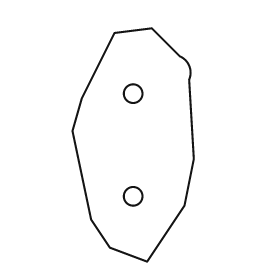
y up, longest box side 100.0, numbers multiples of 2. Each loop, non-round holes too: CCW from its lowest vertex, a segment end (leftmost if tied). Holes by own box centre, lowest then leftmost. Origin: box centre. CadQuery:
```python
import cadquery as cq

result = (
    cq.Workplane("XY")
    .moveTo(6.0, -50.0)
    .lineTo(22.0, -26.0)
    .lineTo(26.0, -6.0)
    .lineTo(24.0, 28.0)
    .threePointArc((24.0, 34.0), (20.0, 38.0))
    .lineTo(8.0, 50.0)
    .lineTo(-8.0, 48.0)
    .lineTo(-22.0, 20.0)
    .lineTo(-26.0, 6.0)
    .lineTo(-18.0, -32.0)
    .lineTo(-10.0, -44.0)
    .close()
    .moveTo(0.0, -22.0)
    .circle(4.0)
    .moveTo(0.0, 22.0)
    .circle(4.0)
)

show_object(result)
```